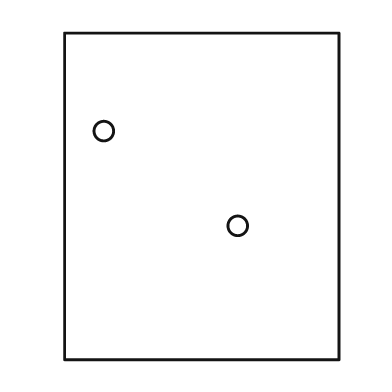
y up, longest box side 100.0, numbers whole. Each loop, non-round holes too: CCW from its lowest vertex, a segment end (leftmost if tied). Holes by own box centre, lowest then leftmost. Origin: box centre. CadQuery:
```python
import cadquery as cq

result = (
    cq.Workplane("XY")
    .moveTo(-42.0, -50.0)
    .lineTo(42.0, -50.0)
    .lineTo(42.0, 50.0)
    .lineTo(-42.0, 50.0)
    .close()
    .moveTo(11.0, -9.0)
    .circle(3.0)
    .moveTo(-30.0, 20.0)
    .circle(3.0)
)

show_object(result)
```